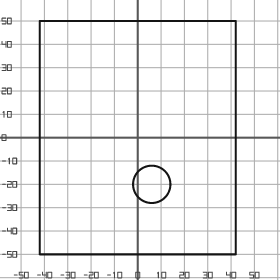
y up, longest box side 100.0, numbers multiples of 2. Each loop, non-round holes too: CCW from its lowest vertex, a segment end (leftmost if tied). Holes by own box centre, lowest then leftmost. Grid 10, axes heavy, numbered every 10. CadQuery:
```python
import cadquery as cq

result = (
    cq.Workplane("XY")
    .moveTo(-42.0, -50.0)
    .lineTo(42.0, -50.0)
    .lineTo(42.0, 50.0)
    .lineTo(-42.0, 50.0)
    .close()
    .moveTo(6.0, -20.0)
    .circle(8.0)
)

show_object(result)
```